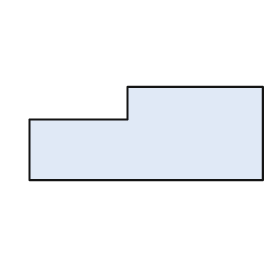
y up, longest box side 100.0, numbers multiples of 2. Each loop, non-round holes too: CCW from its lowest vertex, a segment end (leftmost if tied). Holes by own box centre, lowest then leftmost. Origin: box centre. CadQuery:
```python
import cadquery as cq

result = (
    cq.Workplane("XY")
    .moveTo(-50.0, -20.0)
    .lineTo(50.0, -20.0)
    .lineTo(50.0, 20.0)
    .lineTo(-8.0, 20.0)
    .lineTo(-8.0, 6.0)
    .lineTo(-50.0, 6.0)
    .close()
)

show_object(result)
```